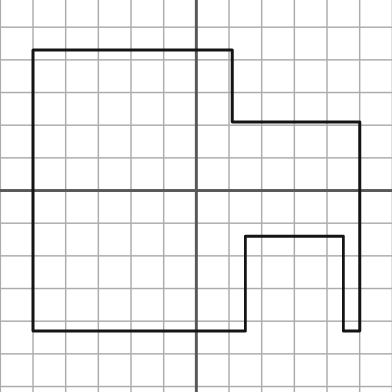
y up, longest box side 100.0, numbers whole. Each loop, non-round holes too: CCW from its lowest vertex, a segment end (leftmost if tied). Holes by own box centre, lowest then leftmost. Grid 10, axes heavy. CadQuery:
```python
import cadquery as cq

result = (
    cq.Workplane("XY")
    .moveTo(-50.0, -43.0)
    .lineTo(15.0, -43.0)
    .lineTo(15.0, -14.0)
    .lineTo(45.0, -14.0)
    .lineTo(45.0, -43.0)
    .lineTo(50.0, -43.0)
    .lineTo(50.0, 21.0)
    .lineTo(11.0, 21.0)
    .lineTo(11.0, 43.0)
    .lineTo(-50.0, 43.0)
    .close()
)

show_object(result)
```